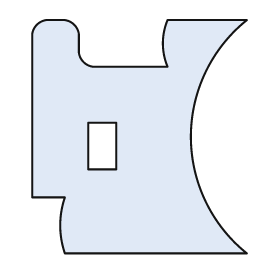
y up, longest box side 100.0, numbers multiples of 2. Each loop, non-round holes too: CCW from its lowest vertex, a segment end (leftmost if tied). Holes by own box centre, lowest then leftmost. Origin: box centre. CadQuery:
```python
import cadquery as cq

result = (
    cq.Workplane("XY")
    .moveTo(-32.0, -50.0)
    .lineTo(46.0, -50.0)
    .threePointArc((22.0, 0.0), (46.0, 50.0))
    .lineTo(12.0, 50.0)
    .threePointArc((10.0, 40.0), (12.0, 30.0))
    .lineTo(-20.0, 30.0)
    .threePointArc((-24.0, 32.0), (-26.0, 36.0))
    .lineTo(-26.0, 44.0)
    .threePointArc((-28.0, 48.0), (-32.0, 50.0))
    .lineTo(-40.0, 50.0)
    .threePointArc((-44.0, 48.0), (-46.0, 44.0))
    .lineTo(-46.0, -26.0)
    .lineTo(-32.0, -26.0)
    .threePointArc((-34.0, -38.0), (-32.0, -50.0))
    .close()
    .moveTo(-22.0, -14.0)
    .lineTo(-10.0, -14.0)
    .lineTo(-10.0, 6.0)
    .lineTo(-22.0, 6.0)
    .close()
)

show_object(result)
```